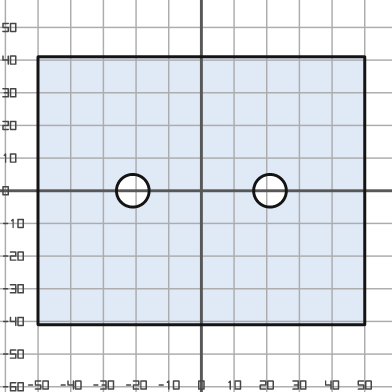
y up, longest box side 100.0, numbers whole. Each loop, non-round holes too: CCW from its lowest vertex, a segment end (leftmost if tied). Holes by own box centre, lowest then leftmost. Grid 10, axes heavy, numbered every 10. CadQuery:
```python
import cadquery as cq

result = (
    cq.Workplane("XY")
    .moveTo(-50.0, -41.0)
    .lineTo(50.0, -41.0)
    .lineTo(50.0, 41.0)
    .lineTo(-50.0, 41.0)
    .close()
    .moveTo(-21.0, 0.0)
    .circle(5.0)
    .moveTo(21.0, 0.0)
    .circle(5.0)
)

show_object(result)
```